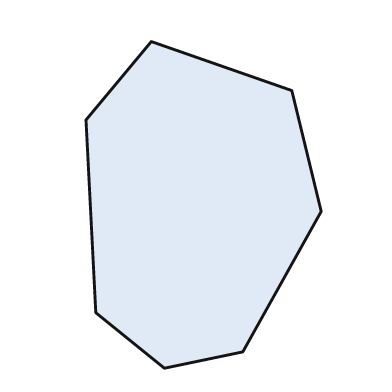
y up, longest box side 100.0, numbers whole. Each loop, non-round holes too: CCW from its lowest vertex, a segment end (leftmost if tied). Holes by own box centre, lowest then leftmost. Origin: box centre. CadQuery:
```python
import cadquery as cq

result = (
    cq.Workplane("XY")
    .moveTo(-12.0, -50.0)
    .lineTo(12.0, -45.0)
    .lineTo(36.0, -2.0)
    .lineTo(27.0, 35.0)
    .lineTo(-16.0, 50.0)
    .lineTo(-36.0, 26.0)
    .lineTo(-33.0, -33.0)
    .close()
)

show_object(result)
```